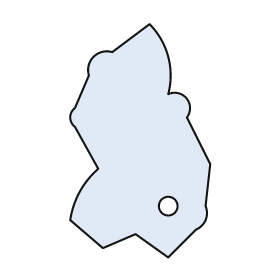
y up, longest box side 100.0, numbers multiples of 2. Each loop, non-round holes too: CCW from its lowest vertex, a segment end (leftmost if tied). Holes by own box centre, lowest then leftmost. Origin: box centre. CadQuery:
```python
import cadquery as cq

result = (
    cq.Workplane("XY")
    .moveTo(12.0, -50.0)
    .lineTo(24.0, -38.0)
    .threePointArc((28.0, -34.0), (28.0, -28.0))
    .lineTo(30.0, -10.0)
    .lineTo(20.0, 10.0)
    .threePointArc((20.0, 18.0), (12.0, 20.0))
    .threePointArc((12.0, 36.0), (4.0, 50.0))
    .lineTo(-12.0, 38.0)
    .threePointArc((-20.0, 36.0), (-22.0, 28.0))
    .lineTo(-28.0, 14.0)
    .threePointArc((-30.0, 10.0), (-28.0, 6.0))
    .lineTo(-18.0, -12.0)
    .threePointArc((-26.0, -22.0), (-30.0, -34.0))
    .lineTo(-16.0, -46.0)
    .lineTo(-2.0, -40.0)
    .close()
    .moveTo(12.0, -28.0)
    .circle(4.0)
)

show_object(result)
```